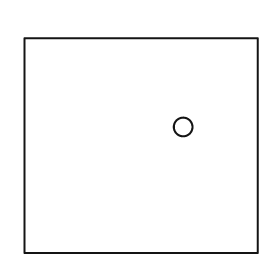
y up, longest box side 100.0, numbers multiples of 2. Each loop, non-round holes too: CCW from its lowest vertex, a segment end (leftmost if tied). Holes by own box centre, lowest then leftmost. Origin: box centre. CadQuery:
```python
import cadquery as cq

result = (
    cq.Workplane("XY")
    .moveTo(-50.0, -46.0)
    .lineTo(50.0, -46.0)
    .lineTo(50.0, 46.0)
    .lineTo(-50.0, 46.0)
    .close()
    .moveTo(18.0, 8.0)
    .circle(4.0)
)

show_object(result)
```